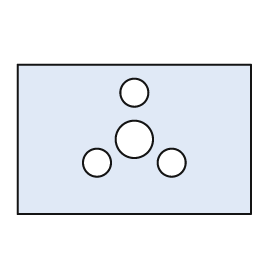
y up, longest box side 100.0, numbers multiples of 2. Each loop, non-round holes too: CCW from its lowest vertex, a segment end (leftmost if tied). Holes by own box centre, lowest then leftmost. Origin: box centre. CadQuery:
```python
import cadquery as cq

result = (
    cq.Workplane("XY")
    .moveTo(-50.0, -32.0)
    .lineTo(50.0, -32.0)
    .lineTo(50.0, 32.0)
    .lineTo(-50.0, 32.0)
    .close()
    .moveTo(-16.0, -10.0)
    .circle(6.0)
    .moveTo(16.0, -10.0)
    .circle(6.0)
    .moveTo(0.0, 0.0)
    .circle(8.0)
    .moveTo(0.0, 20.0)
    .circle(6.0)
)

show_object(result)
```